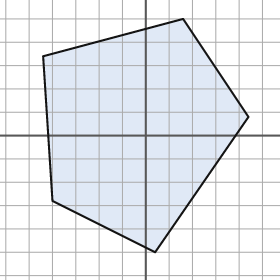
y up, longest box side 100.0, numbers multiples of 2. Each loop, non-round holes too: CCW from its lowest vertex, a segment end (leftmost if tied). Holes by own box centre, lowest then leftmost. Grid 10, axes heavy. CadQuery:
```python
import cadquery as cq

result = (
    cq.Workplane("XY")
    .moveTo(4.0, -50.0)
    .lineTo(44.0, 8.0)
    .lineTo(16.0, 50.0)
    .lineTo(-44.0, 34.0)
    .lineTo(-40.0, -28.0)
    .close()
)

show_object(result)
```